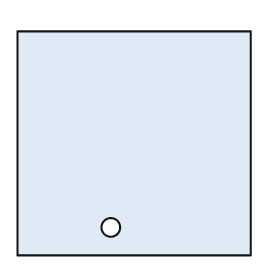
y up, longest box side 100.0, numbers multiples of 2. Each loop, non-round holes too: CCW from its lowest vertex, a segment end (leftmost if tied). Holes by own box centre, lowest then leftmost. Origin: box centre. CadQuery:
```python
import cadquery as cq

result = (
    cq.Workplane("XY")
    .moveTo(-50.0, -48.0)
    .lineTo(50.0, -48.0)
    .lineTo(50.0, 48.0)
    .lineTo(-50.0, 48.0)
    .close()
    .moveTo(-10.0, -36.0)
    .circle(4.0)
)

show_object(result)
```